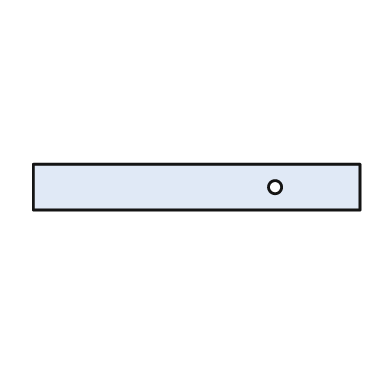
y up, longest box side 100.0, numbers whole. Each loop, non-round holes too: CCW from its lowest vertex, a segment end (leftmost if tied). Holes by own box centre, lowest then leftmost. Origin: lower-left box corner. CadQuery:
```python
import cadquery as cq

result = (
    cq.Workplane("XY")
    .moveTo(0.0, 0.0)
    .lineTo(100.0, 0.0)
    .lineTo(100.0, 14.0)
    .lineTo(0.0, 14.0)
    .close()
    .moveTo(74.0, 7.0)
    .circle(2.0)
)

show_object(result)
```